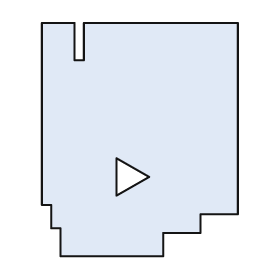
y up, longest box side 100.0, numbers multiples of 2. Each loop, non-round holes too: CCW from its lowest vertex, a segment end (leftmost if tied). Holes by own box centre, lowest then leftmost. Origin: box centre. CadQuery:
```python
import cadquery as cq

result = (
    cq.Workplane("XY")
    .moveTo(-34.0, -50.0)
    .lineTo(10.0, -50.0)
    .lineTo(10.0, -40.0)
    .lineTo(26.0, -40.0)
    .lineTo(26.0, -32.0)
    .lineTo(42.0, -32.0)
    .lineTo(42.0, 50.0)
    .lineTo(-24.0, 50.0)
    .lineTo(-24.0, 34.0)
    .lineTo(-28.0, 34.0)
    .lineTo(-28.0, 50.0)
    .lineTo(-42.0, 50.0)
    .lineTo(-42.0, -28.0)
    .lineTo(-38.0, -28.0)
    .lineTo(-38.0, -38.0)
    .lineTo(-34.0, -38.0)
    .close()
    .moveTo(-10.0, -24.0)
    .lineTo(4.0, -16.0)
    .lineTo(-10.0, -8.0)
    .close()
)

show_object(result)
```